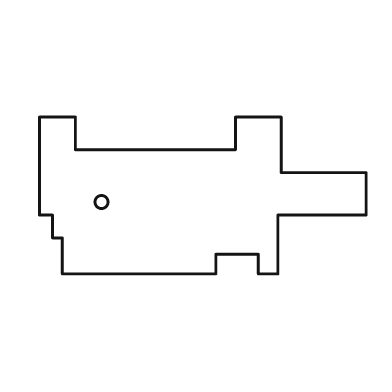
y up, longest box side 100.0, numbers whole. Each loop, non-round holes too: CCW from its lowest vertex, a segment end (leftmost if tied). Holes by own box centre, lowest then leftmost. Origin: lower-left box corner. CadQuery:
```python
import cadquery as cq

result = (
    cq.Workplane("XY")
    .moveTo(7.0, 0.0)
    .lineTo(54.0, 0.0)
    .lineTo(54.0, 6.0)
    .lineTo(67.0, 6.0)
    .lineTo(67.0, 0.0)
    .lineTo(73.0, 0.0)
    .lineTo(73.0, 18.0)
    .lineTo(100.0, 18.0)
    .lineTo(100.0, 31.0)
    .lineTo(74.0, 31.0)
    .lineTo(74.0, 48.0)
    .lineTo(60.0, 48.0)
    .lineTo(60.0, 38.0)
    .lineTo(11.0, 38.0)
    .lineTo(11.0, 48.0)
    .lineTo(0.0, 48.0)
    .lineTo(0.0, 18.0)
    .lineTo(4.0, 18.0)
    .lineTo(4.0, 11.0)
    .lineTo(7.0, 11.0)
    .close()
    .moveTo(19.0, 22.0)
    .circle(2.0)
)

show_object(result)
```